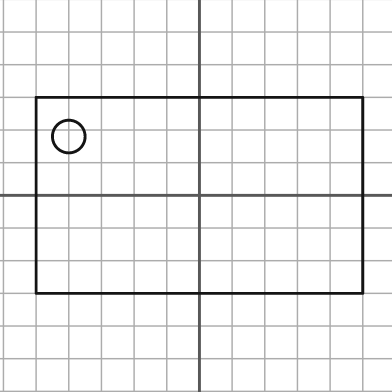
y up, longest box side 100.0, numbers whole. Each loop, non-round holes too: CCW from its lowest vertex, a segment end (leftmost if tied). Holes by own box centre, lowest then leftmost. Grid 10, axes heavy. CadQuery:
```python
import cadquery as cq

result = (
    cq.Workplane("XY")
    .moveTo(-50.0, -30.0)
    .lineTo(50.0, -30.0)
    .lineTo(50.0, 30.0)
    .lineTo(-50.0, 30.0)
    .close()
    .moveTo(-40.0, 18.0)
    .circle(5.0)
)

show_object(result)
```